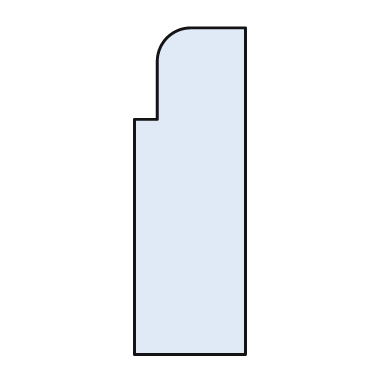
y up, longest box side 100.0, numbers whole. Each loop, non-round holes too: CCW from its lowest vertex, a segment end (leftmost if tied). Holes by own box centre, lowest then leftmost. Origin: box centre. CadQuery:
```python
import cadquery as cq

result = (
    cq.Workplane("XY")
    .moveTo(-17.0, -50.0)
    .lineTo(17.0, -50.0)
    .lineTo(17.0, 50.0)
    .lineTo(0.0, 50.0)
    .threePointArc((-7.0, 47.0), (-10.0, 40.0))
    .lineTo(-10.0, 22.0)
    .lineTo(-17.0, 22.0)
    .close()
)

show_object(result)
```